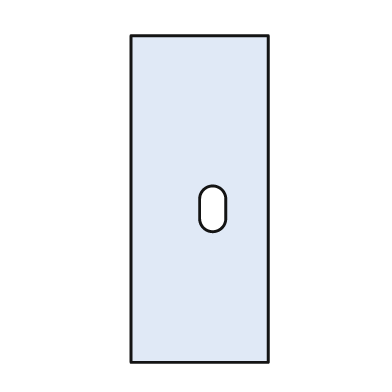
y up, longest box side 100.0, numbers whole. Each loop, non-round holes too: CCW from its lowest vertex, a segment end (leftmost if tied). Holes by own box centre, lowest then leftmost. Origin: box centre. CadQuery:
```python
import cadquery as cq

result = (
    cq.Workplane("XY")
    .moveTo(-21.0, -50.0)
    .lineTo(21.0, -50.0)
    .lineTo(21.0, 50.0)
    .lineTo(-21.0, 50.0)
    .close()
    .moveTo(0.0, -6.0)
    .threePointArc((4.0, -10.0), (8.0, -6.0))
    .lineTo(8.0, 0.0)
    .threePointArc((4.0, 4.0), (0.0, 0.0))
    .close()
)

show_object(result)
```